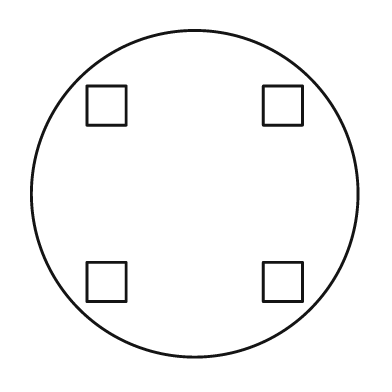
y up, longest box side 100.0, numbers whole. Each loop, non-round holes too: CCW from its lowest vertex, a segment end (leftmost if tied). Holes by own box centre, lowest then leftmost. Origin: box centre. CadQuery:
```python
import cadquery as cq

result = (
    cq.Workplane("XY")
    .moveTo(0.0, 0.0)
    .circle(50.0)
    .moveTo(-33.0, -33.0)
    .lineTo(-21.0, -33.0)
    .lineTo(-21.0, -21.0)
    .lineTo(-33.0, -21.0)
    .close()
    .moveTo(21.0, -33.0)
    .lineTo(33.0, -33.0)
    .lineTo(33.0, -21.0)
    .lineTo(21.0, -21.0)
    .close()
    .moveTo(-33.0, 21.0)
    .lineTo(-21.0, 21.0)
    .lineTo(-21.0, 33.0)
    .lineTo(-33.0, 33.0)
    .close()
    .moveTo(21.0, 21.0)
    .lineTo(33.0, 21.0)
    .lineTo(33.0, 33.0)
    .lineTo(21.0, 33.0)
    .close()
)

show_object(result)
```